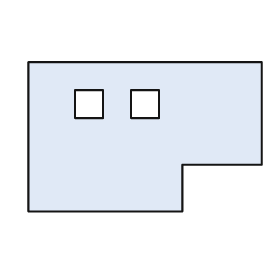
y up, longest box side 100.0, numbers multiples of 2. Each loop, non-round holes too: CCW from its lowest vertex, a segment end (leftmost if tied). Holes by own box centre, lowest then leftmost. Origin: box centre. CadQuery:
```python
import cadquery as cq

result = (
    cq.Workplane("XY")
    .moveTo(-50.0, -32.0)
    .lineTo(16.0, -32.0)
    .lineTo(16.0, -12.0)
    .lineTo(50.0, -12.0)
    .lineTo(50.0, 32.0)
    .lineTo(-50.0, 32.0)
    .close()
    .moveTo(-30.0, 8.0)
    .lineTo(-18.0, 8.0)
    .lineTo(-18.0, 20.0)
    .lineTo(-30.0, 20.0)
    .close()
    .moveTo(-6.0, 8.0)
    .lineTo(6.0, 8.0)
    .lineTo(6.0, 20.0)
    .lineTo(-6.0, 20.0)
    .close()
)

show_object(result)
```